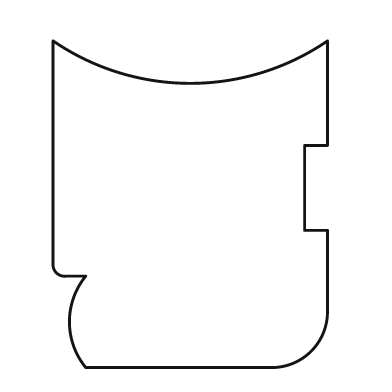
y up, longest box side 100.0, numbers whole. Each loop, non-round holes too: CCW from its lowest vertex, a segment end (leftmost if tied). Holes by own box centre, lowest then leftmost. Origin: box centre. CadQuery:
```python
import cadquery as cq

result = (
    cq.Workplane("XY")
    .moveTo(-32.0, -50.0)
    .lineTo(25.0, -50.0)
    .threePointArc((37.0, -45.0), (42.0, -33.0))
    .lineTo(42.0, -8.0)
    .lineTo(35.0, -8.0)
    .lineTo(35.0, 18.0)
    .lineTo(42.0, 18.0)
    .lineTo(42.0, 50.0)
    .threePointArc((0.0, 37.0), (-42.0, 50.0))
    .lineTo(-42.0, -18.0)
    .threePointArc((-41.0, -21.0), (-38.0, -22.0))
    .lineTo(-32.0, -22.0)
    .threePointArc((-37.0, -36.0), (-32.0, -50.0))
    .close()
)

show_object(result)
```